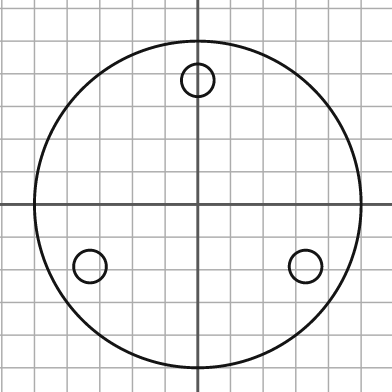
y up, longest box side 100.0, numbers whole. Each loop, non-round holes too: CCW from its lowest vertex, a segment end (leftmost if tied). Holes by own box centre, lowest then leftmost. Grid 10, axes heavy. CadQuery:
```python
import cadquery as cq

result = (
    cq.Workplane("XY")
    .moveTo(0.0, 0.0)
    .circle(50.0)
    .moveTo(-33.0, -19.0)
    .circle(5.0)
    .moveTo(33.0, -19.0)
    .circle(5.0)
    .moveTo(0.0, 38.0)
    .circle(5.0)
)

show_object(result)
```